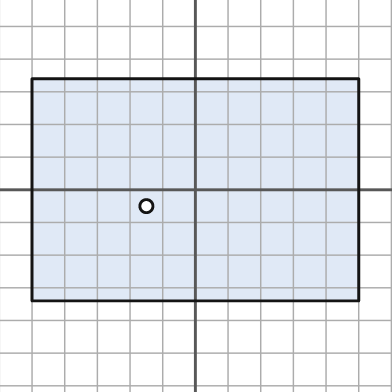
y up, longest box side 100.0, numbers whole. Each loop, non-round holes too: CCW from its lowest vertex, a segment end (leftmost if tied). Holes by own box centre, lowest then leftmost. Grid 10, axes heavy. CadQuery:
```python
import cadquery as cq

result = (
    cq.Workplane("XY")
    .moveTo(-50.0, -34.0)
    .lineTo(50.0, -34.0)
    .lineTo(50.0, 34.0)
    .lineTo(-50.0, 34.0)
    .close()
    .moveTo(-15.0, -5.0)
    .circle(2.0)
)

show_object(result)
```